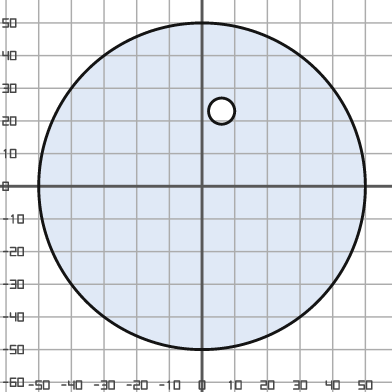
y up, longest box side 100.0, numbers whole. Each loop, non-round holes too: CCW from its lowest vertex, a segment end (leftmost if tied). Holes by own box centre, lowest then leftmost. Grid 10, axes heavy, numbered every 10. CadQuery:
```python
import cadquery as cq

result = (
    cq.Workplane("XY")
    .moveTo(0.0, 0.0)
    .circle(50.0)
    .moveTo(6.0, 23.0)
    .circle(4.0)
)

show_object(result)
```